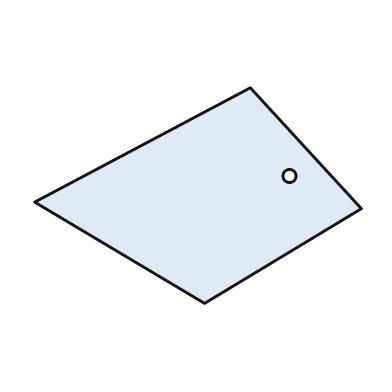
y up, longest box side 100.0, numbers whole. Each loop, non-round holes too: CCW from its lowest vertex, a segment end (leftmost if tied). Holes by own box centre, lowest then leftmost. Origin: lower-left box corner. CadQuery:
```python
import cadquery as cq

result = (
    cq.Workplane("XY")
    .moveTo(52.0, 0.0)
    .lineTo(100.0, 29.0)
    .lineTo(66.0, 66.0)
    .lineTo(0.0, 31.0)
    .close()
    .moveTo(78.0, 39.0)
    .circle(2.0)
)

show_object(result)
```